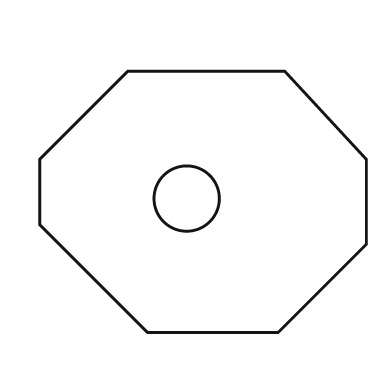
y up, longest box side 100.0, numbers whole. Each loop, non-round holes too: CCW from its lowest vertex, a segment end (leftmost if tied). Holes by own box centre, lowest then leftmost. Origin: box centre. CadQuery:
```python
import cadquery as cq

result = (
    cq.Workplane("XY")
    .moveTo(-17.0, -40.0)
    .lineTo(23.0, -40.0)
    .lineTo(50.0, -13.0)
    .lineTo(50.0, 13.0)
    .lineTo(25.0, 40.0)
    .lineTo(-23.0, 40.0)
    .lineTo(-50.0, 13.0)
    .lineTo(-50.0, -7.0)
    .close()
    .moveTo(-5.0, 1.0)
    .circle(10.0)
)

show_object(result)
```